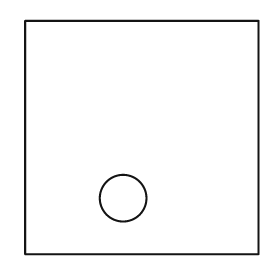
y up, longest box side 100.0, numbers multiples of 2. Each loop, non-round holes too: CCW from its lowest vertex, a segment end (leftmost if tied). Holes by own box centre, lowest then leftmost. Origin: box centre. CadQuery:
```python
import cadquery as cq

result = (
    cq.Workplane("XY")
    .moveTo(-50.0, -50.0)
    .lineTo(50.0, -50.0)
    .lineTo(50.0, 50.0)
    .lineTo(-50.0, 50.0)
    .close()
    .moveTo(-8.0, -26.0)
    .circle(10.0)
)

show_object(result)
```